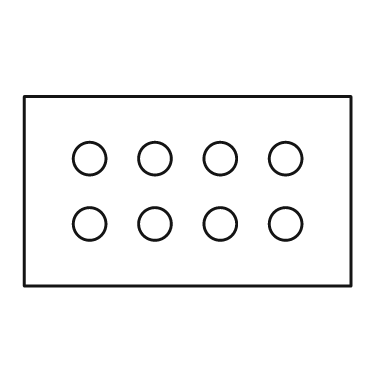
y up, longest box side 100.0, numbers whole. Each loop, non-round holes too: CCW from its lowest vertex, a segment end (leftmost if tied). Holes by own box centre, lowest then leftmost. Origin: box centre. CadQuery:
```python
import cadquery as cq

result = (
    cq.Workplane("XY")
    .moveTo(-50.0, -29.0)
    .lineTo(50.0, -29.0)
    .lineTo(50.0, 29.0)
    .lineTo(-50.0, 29.0)
    .close()
    .moveTo(-30.0, -10.0)
    .circle(5.0)
    .moveTo(-10.0, -10.0)
    .circle(5.0)
    .moveTo(10.0, -10.0)
    .circle(5.0)
    .moveTo(30.0, -10.0)
    .circle(5.0)
    .moveTo(-30.0, 10.0)
    .circle(5.0)
    .moveTo(-10.0, 10.0)
    .circle(5.0)
    .moveTo(10.0, 10.0)
    .circle(5.0)
    .moveTo(30.0, 10.0)
    .circle(5.0)
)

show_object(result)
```